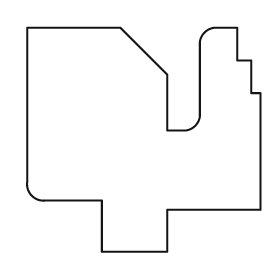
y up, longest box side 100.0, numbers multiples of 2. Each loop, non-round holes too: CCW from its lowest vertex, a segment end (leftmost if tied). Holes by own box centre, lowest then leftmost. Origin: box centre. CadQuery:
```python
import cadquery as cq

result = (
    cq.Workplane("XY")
    .moveTo(-18.0, -48.0)
    .lineTo(10.0, -48.0)
    .lineTo(10.0, -30.0)
    .lineTo(50.0, -30.0)
    .lineTo(50.0, 20.0)
    .lineTo(46.0, 20.0)
    .lineTo(46.0, 34.0)
    .lineTo(40.0, 34.0)
    .lineTo(40.0, 48.0)
    .lineTo(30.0, 48.0)
    .threePointArc((26.0, 46.0), (24.0, 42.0))
    .lineTo(24.0, 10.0)
    .threePointArc((22.0, 6.0), (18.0, 4.0))
    .lineTo(10.0, 4.0)
    .lineTo(10.0, 28.0)
    .lineTo(-10.0, 48.0)
    .lineTo(-50.0, 48.0)
    .lineTo(-50.0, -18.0)
    .threePointArc((-48.0, -24.0), (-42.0, -26.0))
    .lineTo(-18.0, -26.0)
    .close()
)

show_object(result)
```